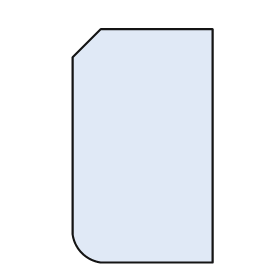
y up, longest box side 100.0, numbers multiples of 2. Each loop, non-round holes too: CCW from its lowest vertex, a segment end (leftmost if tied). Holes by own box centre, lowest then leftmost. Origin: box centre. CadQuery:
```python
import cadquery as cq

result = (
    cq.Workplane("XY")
    .moveTo(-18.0, -50.0)
    .lineTo(30.0, -50.0)
    .lineTo(30.0, 50.0)
    .lineTo(-18.0, 50.0)
    .lineTo(-30.0, 38.0)
    .lineTo(-30.0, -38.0)
    .threePointArc((-26.0, -46.0), (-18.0, -50.0))
    .close()
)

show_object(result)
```